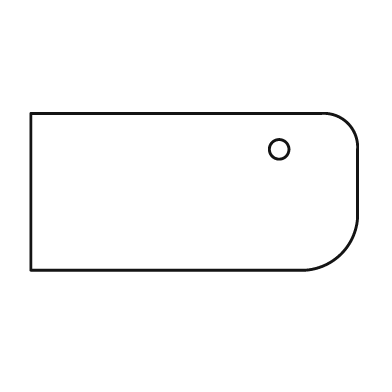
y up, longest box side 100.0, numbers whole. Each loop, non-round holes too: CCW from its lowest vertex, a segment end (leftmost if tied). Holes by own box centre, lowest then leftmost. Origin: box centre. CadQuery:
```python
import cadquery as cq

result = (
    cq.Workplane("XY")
    .moveTo(-50.0, -24.0)
    .lineTo(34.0, -24.0)
    .threePointArc((45.0, -19.0), (50.0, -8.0))
    .lineTo(50.0, 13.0)
    .threePointArc((47.0, 21.0), (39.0, 24.0))
    .lineTo(-50.0, 24.0)
    .close()
    .moveTo(26.0, 13.0)
    .circle(3.0)
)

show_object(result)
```